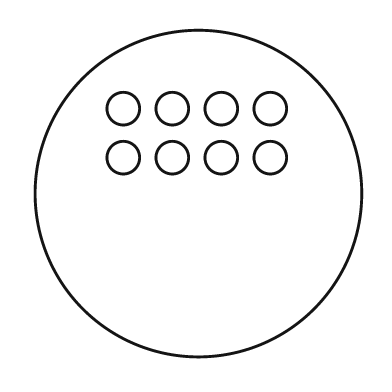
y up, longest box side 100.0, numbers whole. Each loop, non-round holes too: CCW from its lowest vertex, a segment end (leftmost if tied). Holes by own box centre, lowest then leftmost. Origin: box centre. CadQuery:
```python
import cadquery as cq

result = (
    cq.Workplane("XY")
    .moveTo(0.0, 0.0)
    .circle(50.0)
    .moveTo(-23.0, 11.0)
    .circle(5.0)
    .moveTo(-8.0, 11.0)
    .circle(5.0)
    .moveTo(7.0, 11.0)
    .circle(5.0)
    .moveTo(22.0, 11.0)
    .circle(5.0)
    .moveTo(-23.0, 26.0)
    .circle(5.0)
    .moveTo(-8.0, 26.0)
    .circle(5.0)
    .moveTo(7.0, 26.0)
    .circle(5.0)
    .moveTo(22.0, 26.0)
    .circle(5.0)
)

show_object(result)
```